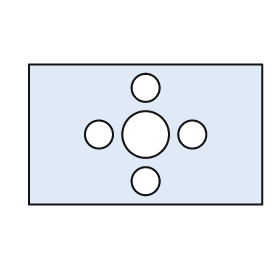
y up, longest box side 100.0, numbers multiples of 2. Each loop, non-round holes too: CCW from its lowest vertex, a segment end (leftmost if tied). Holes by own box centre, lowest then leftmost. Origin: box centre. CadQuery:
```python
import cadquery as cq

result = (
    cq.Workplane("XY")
    .moveTo(-50.0, -30.0)
    .lineTo(50.0, -30.0)
    .lineTo(50.0, 30.0)
    .lineTo(-50.0, 30.0)
    .close()
    .moveTo(0.0, -20.0)
    .circle(6.0)
    .moveTo(-20.0, 0.0)
    .circle(6.0)
    .moveTo(0.0, 0.0)
    .circle(10.0)
    .moveTo(20.0, 0.0)
    .circle(6.0)
    .moveTo(0.0, 20.0)
    .circle(6.0)
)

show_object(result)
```